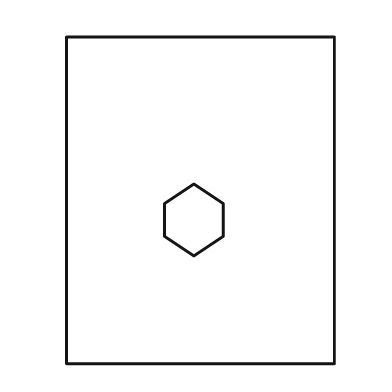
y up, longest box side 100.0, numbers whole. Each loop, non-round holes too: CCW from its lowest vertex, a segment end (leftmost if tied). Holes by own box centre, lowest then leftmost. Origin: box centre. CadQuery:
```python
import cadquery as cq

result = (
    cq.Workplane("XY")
    .moveTo(-41.0, -50.0)
    .lineTo(41.0, -50.0)
    .lineTo(41.0, 50.0)
    .lineTo(-41.0, 50.0)
    .close()
    .moveTo(-2.0, -17.0)
    .lineTo(7.0, -11.0)
    .lineTo(7.0, -1.0)
    .lineTo(-2.0, 5.0)
    .lineTo(-11.0, -1.0)
    .lineTo(-11.0, -11.0)
    .close()
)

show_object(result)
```